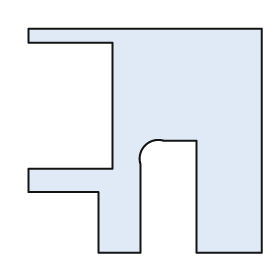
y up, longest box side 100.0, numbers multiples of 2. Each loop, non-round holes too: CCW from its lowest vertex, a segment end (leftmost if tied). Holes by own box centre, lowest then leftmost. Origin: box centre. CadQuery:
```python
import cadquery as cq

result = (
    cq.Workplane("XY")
    .moveTo(-20.0, -48.0)
    .lineTo(-2.0, -48.0)
    .lineTo(-2.0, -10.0)
    .threePointArc((0.0, -2.0), (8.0, 0.0))
    .lineTo(22.0, 0.0)
    .lineTo(22.0, -48.0)
    .lineTo(50.0, -48.0)
    .lineTo(50.0, 48.0)
    .lineTo(-50.0, 48.0)
    .lineTo(-50.0, 42.0)
    .lineTo(-14.0, 42.0)
    .lineTo(-14.0, -12.0)
    .lineTo(-50.0, -12.0)
    .lineTo(-50.0, -22.0)
    .lineTo(-20.0, -22.0)
    .close()
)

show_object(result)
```